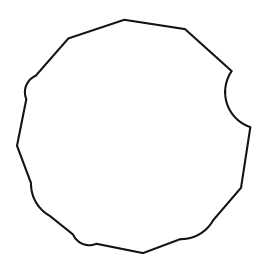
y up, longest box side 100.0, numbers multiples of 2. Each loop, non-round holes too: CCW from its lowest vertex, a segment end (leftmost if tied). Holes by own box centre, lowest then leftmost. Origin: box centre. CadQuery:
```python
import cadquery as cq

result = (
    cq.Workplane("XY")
    .moveTo(4.0, -50.0)
    .lineTo(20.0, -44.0)
    .threePointArc((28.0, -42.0), (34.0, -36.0))
    .lineTo(46.0, -22.0)
    .lineTo(50.0, 4.0)
    .threePointArc((40.0, 14.0), (42.0, 28.0))
    .lineTo(22.0, 46.0)
    .lineTo(-4.0, 50.0)
    .lineTo(-28.0, 42.0)
    .lineTo(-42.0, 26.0)
    .threePointArc((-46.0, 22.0), (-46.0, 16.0))
    .lineTo(-50.0, -4.0)
    .lineTo(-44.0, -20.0)
    .threePointArc((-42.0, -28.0), (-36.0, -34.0))
    .lineTo(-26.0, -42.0)
    .threePointArc((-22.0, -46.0), (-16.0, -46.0))
    .close()
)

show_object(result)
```